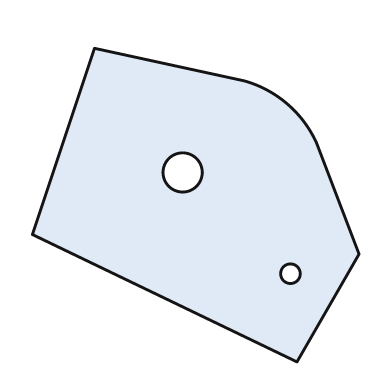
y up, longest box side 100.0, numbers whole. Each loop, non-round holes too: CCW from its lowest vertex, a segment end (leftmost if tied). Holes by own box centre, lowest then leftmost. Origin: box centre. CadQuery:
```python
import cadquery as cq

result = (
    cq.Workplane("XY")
    .moveTo(31.0, -48.0)
    .lineTo(50.0, -15.0)
    .lineTo(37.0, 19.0)
    .threePointArc((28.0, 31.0), (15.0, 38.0))
    .lineTo(-31.0, 48.0)
    .lineTo(-50.0, -9.0)
    .close()
    .moveTo(29.0, -21.0)
    .circle(3.0)
    .moveTo(-4.0, 10.0)
    .circle(6.0)
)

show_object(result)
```